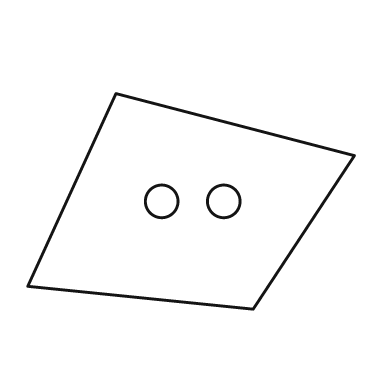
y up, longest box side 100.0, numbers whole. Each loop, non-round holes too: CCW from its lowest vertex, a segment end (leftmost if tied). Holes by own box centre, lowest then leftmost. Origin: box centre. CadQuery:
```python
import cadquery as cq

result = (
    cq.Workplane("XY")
    .moveTo(19.0, -33.0)
    .lineTo(50.0, 14.0)
    .lineTo(-23.0, 33.0)
    .lineTo(-50.0, -26.0)
    .close()
    .moveTo(-9.0, 0.0)
    .circle(5.0)
    .moveTo(10.0, 0.0)
    .circle(5.0)
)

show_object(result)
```